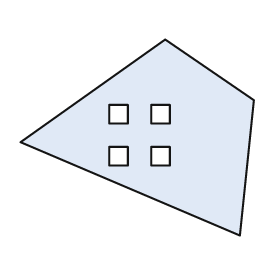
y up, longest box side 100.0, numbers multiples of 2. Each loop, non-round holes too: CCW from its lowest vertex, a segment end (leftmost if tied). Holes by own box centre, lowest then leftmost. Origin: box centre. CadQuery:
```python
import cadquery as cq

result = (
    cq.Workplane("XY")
    .moveTo(44.0, -42.0)
    .lineTo(50.0, 16.0)
    .lineTo(12.0, 42.0)
    .lineTo(-50.0, -2.0)
    .close()
    .moveTo(-12.0, -12.0)
    .lineTo(-4.0, -12.0)
    .lineTo(-4.0, -4.0)
    .lineTo(-12.0, -4.0)
    .close()
    .moveTo(6.0, -12.0)
    .lineTo(14.0, -12.0)
    .lineTo(14.0, -4.0)
    .lineTo(6.0, -4.0)
    .close()
    .moveTo(-12.0, 6.0)
    .lineTo(-4.0, 6.0)
    .lineTo(-4.0, 14.0)
    .lineTo(-12.0, 14.0)
    .close()
    .moveTo(6.0, 6.0)
    .lineTo(14.0, 6.0)
    .lineTo(14.0, 14.0)
    .lineTo(6.0, 14.0)
    .close()
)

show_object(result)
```